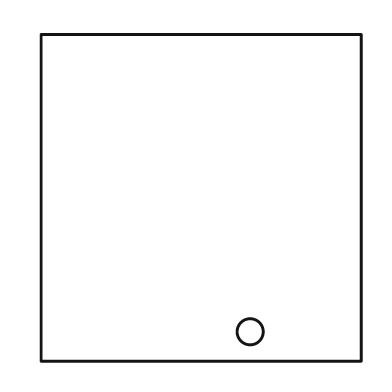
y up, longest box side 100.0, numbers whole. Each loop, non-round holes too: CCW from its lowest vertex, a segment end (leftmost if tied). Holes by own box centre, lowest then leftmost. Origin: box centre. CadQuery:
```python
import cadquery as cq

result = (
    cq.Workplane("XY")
    .moveTo(-49.0, -50.0)
    .lineTo(49.0, -50.0)
    .lineTo(49.0, 50.0)
    .lineTo(-49.0, 50.0)
    .close()
    .moveTo(15.0, -41.0)
    .circle(4.0)
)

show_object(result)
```